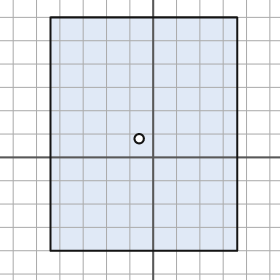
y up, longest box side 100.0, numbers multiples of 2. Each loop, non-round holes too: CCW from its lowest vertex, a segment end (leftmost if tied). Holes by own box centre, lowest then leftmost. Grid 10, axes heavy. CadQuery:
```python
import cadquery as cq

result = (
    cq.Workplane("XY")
    .moveTo(-44.0, -40.0)
    .lineTo(36.0, -40.0)
    .lineTo(36.0, 60.0)
    .lineTo(-44.0, 60.0)
    .close()
    .moveTo(-6.0, 8.0)
    .circle(2.0)
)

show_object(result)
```